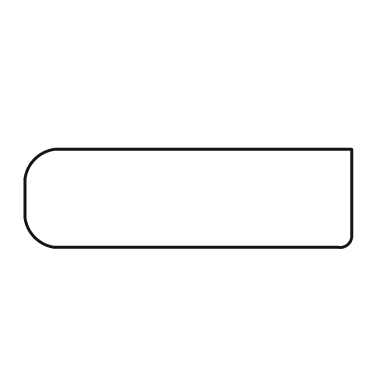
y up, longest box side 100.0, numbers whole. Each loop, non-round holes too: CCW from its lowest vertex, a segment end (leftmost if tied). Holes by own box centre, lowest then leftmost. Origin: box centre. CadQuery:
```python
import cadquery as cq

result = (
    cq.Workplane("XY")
    .moveTo(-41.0, -15.0)
    .lineTo(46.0, -15.0)
    .threePointArc((49.0, -14.0), (50.0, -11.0))
    .lineTo(50.0, 15.0)
    .lineTo(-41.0, 15.0)
    .threePointArc((-47.0, 12.0), (-50.0, 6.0))
    .lineTo(-50.0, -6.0)
    .threePointArc((-47.0, -12.0), (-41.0, -15.0))
    .close()
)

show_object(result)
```